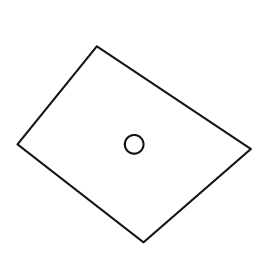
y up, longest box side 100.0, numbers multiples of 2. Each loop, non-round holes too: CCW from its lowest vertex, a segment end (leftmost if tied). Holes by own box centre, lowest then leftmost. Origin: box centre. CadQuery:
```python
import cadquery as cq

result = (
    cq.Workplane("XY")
    .moveTo(4.0, -42.0)
    .lineTo(50.0, -2.0)
    .lineTo(-16.0, 42.0)
    .lineTo(-50.0, 0.0)
    .close()
    .moveTo(0.0, 0.0)
    .circle(4.0)
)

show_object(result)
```